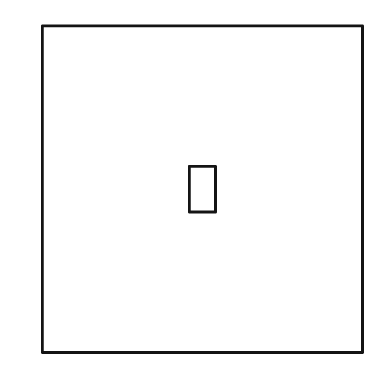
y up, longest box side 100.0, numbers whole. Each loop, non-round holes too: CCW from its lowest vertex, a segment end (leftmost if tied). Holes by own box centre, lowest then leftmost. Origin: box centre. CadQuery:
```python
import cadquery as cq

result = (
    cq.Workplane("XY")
    .moveTo(-49.0, -50.0)
    .lineTo(49.0, -50.0)
    .lineTo(49.0, 50.0)
    .lineTo(-49.0, 50.0)
    .close()
    .moveTo(-4.0, -7.0)
    .lineTo(4.0, -7.0)
    .lineTo(4.0, 7.0)
    .lineTo(-4.0, 7.0)
    .close()
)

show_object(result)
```